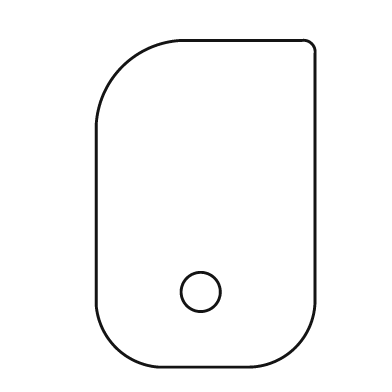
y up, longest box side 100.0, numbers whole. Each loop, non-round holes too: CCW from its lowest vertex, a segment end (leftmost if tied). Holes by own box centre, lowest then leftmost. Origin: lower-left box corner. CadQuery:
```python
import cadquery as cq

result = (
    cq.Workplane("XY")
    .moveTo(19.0, 0.0)
    .lineTo(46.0, 0.0)
    .threePointArc((61.0, 6.0), (67.0, 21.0))
    .lineTo(67.0, 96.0)
    .threePointArc((66.0, 99.0), (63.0, 100.0))
    .lineTo(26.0, 100.0)
    .threePointArc((8.0, 92.0), (0.0, 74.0))
    .lineTo(0.0, 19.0)
    .threePointArc((6.0, 6.0), (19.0, 0.0))
    .close()
    .moveTo(32.0, 23.0)
    .circle(6.0)
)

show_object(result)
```